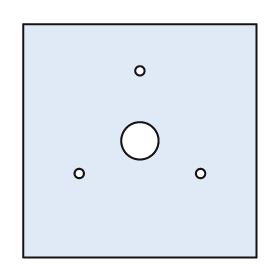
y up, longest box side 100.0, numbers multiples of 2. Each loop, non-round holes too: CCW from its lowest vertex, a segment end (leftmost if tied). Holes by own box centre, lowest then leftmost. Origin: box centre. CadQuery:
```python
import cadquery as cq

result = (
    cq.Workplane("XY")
    .moveTo(-50.0, -50.0)
    .lineTo(50.0, -50.0)
    .lineTo(50.0, 50.0)
    .lineTo(-50.0, 50.0)
    .close()
    .moveTo(-26.0, -14.0)
    .circle(2.0)
    .moveTo(26.0, -14.0)
    .circle(2.0)
    .moveTo(0.0, 0.0)
    .circle(8.0)
    .moveTo(0.0, 30.0)
    .circle(2.0)
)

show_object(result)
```